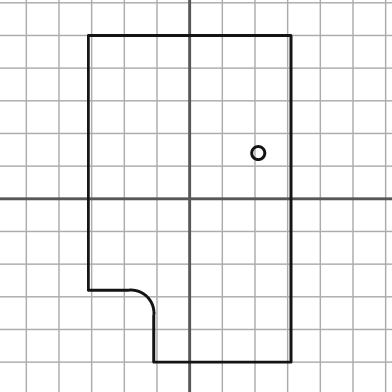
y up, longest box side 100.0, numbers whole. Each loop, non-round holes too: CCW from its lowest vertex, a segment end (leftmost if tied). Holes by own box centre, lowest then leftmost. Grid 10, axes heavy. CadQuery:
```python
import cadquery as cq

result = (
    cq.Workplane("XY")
    .moveTo(-11.0, -50.0)
    .lineTo(31.0, -50.0)
    .lineTo(31.0, 50.0)
    .lineTo(-31.0, 50.0)
    .lineTo(-31.0, -28.0)
    .lineTo(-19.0, -28.0)
    .threePointArc((-13.0, -30.0), (-11.0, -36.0))
    .close()
    .moveTo(21.0, 14.0)
    .circle(2.0)
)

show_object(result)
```